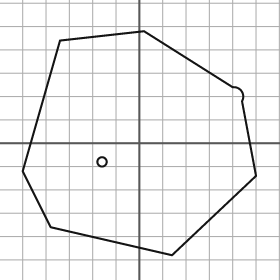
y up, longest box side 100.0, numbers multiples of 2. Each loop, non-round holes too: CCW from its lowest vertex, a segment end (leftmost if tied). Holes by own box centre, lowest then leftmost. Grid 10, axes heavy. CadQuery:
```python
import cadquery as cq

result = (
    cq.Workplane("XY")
    .moveTo(14.0, -48.0)
    .lineTo(50.0, -14.0)
    .lineTo(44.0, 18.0)
    .threePointArc((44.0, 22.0), (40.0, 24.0))
    .lineTo(2.0, 48.0)
    .lineTo(-34.0, 44.0)
    .lineTo(-50.0, -12.0)
    .lineTo(-38.0, -36.0)
    .close()
    .moveTo(-16.0, -8.0)
    .circle(2.0)
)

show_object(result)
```